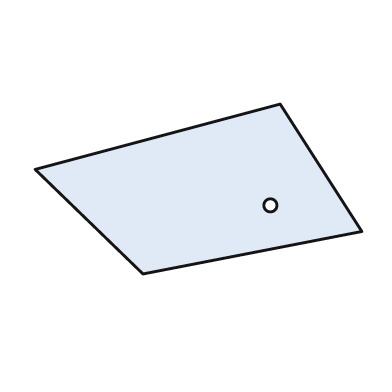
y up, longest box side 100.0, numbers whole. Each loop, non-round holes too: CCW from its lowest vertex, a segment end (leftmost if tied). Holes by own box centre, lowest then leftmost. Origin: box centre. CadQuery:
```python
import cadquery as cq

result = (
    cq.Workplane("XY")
    .moveTo(-17.0, -26.0)
    .lineTo(50.0, -13.0)
    .lineTo(25.0, 26.0)
    .lineTo(-50.0, 6.0)
    .close()
    .moveTo(22.0, -5.0)
    .circle(2.0)
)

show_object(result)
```